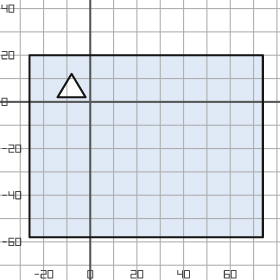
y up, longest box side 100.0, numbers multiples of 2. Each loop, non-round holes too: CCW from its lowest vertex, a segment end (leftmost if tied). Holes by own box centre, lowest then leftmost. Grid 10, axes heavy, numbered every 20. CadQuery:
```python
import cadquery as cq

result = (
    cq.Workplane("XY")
    .moveTo(-26.0, -58.0)
    .lineTo(74.0, -58.0)
    .lineTo(74.0, 20.0)
    .lineTo(-26.0, 20.0)
    .close()
    .moveTo(-14.0, 2.0)
    .lineTo(-2.0, 2.0)
    .lineTo(-8.0, 12.0)
    .close()
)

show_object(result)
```